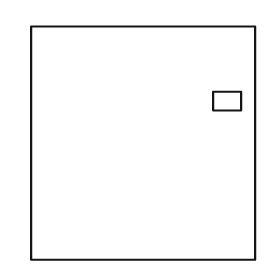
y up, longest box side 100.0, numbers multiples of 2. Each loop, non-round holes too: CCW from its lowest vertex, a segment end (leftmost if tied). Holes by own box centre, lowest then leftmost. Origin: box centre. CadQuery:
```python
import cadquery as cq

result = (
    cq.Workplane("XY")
    .moveTo(-48.0, -50.0)
    .lineTo(48.0, -50.0)
    .lineTo(48.0, 50.0)
    .lineTo(-48.0, 50.0)
    .close()
    .moveTo(30.0, 14.0)
    .lineTo(42.0, 14.0)
    .lineTo(42.0, 22.0)
    .lineTo(30.0, 22.0)
    .close()
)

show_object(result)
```